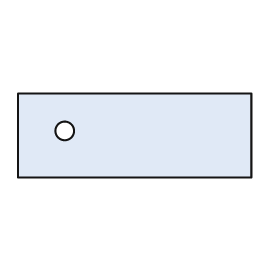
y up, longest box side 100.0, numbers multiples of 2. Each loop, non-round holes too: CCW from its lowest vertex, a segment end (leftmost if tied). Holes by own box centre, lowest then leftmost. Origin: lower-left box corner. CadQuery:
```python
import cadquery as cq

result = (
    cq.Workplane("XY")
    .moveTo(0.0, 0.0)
    .lineTo(100.0, 0.0)
    .lineTo(100.0, 36.0)
    .lineTo(0.0, 36.0)
    .close()
    .moveTo(20.0, 20.0)
    .circle(4.0)
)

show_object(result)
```